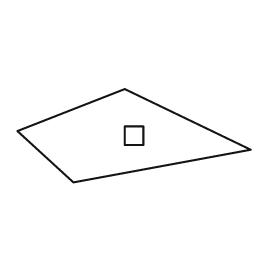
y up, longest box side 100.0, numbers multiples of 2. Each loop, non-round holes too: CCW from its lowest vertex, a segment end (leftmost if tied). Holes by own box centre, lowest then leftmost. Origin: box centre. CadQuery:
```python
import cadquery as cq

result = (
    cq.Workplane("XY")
    .moveTo(-26.0, -20.0)
    .lineTo(50.0, -6.0)
    .lineTo(-4.0, 20.0)
    .lineTo(-50.0, 2.0)
    .close()
    .moveTo(-4.0, -4.0)
    .lineTo(4.0, -4.0)
    .lineTo(4.0, 4.0)
    .lineTo(-4.0, 4.0)
    .close()
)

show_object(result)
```